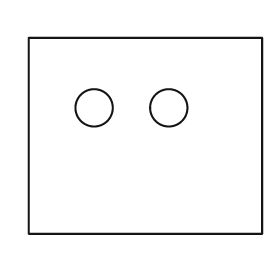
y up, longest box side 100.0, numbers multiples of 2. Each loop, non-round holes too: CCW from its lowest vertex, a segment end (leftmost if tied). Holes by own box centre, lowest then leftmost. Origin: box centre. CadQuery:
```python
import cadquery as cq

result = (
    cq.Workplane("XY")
    .moveTo(-50.0, -42.0)
    .lineTo(50.0, -42.0)
    .lineTo(50.0, 42.0)
    .lineTo(-50.0, 42.0)
    .close()
    .moveTo(-22.0, 12.0)
    .circle(8.0)
    .moveTo(10.0, 12.0)
    .circle(8.0)
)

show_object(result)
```